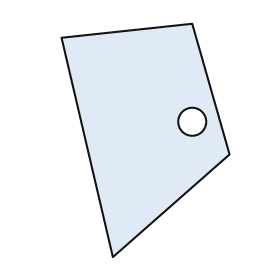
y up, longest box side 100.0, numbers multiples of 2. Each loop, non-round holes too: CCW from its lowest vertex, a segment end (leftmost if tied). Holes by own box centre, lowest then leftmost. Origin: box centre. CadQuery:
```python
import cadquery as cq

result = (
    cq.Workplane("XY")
    .moveTo(-14.0, -50.0)
    .lineTo(36.0, -6.0)
    .lineTo(20.0, 50.0)
    .lineTo(-36.0, 44.0)
    .close()
    .moveTo(20.0, 8.0)
    .circle(6.0)
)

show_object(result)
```